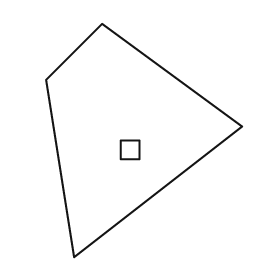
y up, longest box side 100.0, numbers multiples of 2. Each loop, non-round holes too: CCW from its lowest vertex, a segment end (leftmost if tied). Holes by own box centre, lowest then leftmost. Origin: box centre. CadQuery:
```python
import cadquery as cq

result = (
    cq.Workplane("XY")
    .moveTo(-30.0, -50.0)
    .lineTo(42.0, 6.0)
    .lineTo(-18.0, 50.0)
    .lineTo(-42.0, 26.0)
    .close()
    .moveTo(-10.0, -8.0)
    .lineTo(-2.0, -8.0)
    .lineTo(-2.0, 0.0)
    .lineTo(-10.0, 0.0)
    .close()
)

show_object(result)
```